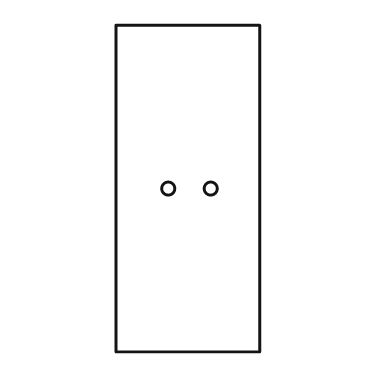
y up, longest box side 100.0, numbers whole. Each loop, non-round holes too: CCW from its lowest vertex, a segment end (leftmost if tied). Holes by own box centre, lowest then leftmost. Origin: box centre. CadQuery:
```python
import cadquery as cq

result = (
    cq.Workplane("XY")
    .moveTo(-22.0, -50.0)
    .lineTo(22.0, -50.0)
    .lineTo(22.0, 50.0)
    .lineTo(-22.0, 50.0)
    .close()
    .moveTo(-6.0, 0.0)
    .circle(2.0)
    .moveTo(7.0, 0.0)
    .circle(2.0)
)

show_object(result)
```